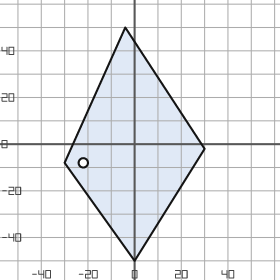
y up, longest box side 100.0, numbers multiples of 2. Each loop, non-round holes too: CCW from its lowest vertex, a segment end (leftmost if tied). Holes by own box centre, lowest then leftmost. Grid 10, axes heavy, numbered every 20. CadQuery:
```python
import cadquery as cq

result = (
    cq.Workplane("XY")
    .moveTo(0.0, -50.0)
    .lineTo(30.0, -2.0)
    .lineTo(-4.0, 50.0)
    .lineTo(-30.0, -8.0)
    .close()
    .moveTo(-22.0, -8.0)
    .circle(2.0)
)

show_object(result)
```